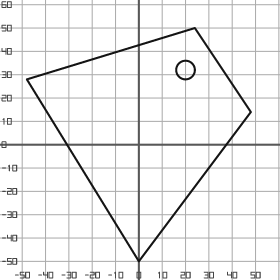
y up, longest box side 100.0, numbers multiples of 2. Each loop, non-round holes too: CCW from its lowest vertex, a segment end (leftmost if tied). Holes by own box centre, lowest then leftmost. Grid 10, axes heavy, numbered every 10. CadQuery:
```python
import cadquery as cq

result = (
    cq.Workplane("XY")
    .moveTo(0.0, -50.0)
    .lineTo(48.0, 14.0)
    .lineTo(24.0, 50.0)
    .lineTo(-48.0, 28.0)
    .close()
    .moveTo(20.0, 32.0)
    .circle(4.0)
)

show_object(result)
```